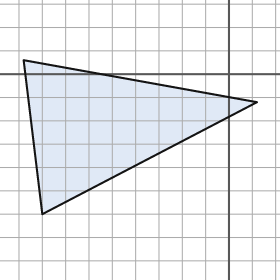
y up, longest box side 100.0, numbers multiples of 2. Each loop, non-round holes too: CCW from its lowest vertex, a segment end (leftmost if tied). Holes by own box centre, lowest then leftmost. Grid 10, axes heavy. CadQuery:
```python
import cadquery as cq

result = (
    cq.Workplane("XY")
    .moveTo(-80.0, -60.0)
    .lineTo(12.0, -12.0)
    .lineTo(-88.0, 6.0)
    .close()
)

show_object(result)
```